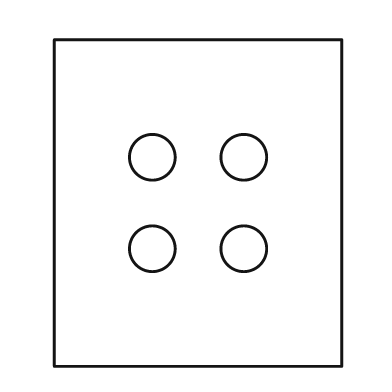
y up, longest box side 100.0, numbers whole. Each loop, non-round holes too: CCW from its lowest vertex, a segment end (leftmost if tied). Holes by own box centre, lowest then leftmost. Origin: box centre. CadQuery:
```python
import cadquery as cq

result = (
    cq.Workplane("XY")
    .moveTo(-44.0, -50.0)
    .lineTo(44.0, -50.0)
    .lineTo(44.0, 50.0)
    .lineTo(-44.0, 50.0)
    .close()
    .moveTo(-14.0, -14.0)
    .circle(7.0)
    .moveTo(14.0, -14.0)
    .circle(7.0)
    .moveTo(-14.0, 14.0)
    .circle(7.0)
    .moveTo(14.0, 14.0)
    .circle(7.0)
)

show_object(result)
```